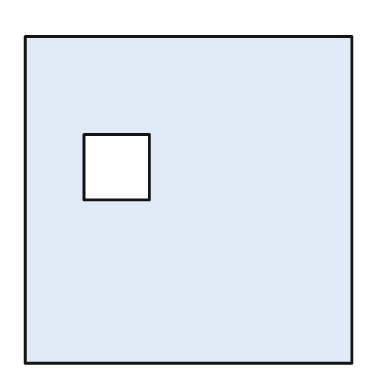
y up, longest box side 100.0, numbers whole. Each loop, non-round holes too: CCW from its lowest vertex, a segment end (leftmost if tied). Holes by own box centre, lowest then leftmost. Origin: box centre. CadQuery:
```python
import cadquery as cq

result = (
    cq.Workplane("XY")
    .moveTo(-50.0, -50.0)
    .lineTo(50.0, -50.0)
    .lineTo(50.0, 50.0)
    .lineTo(-50.0, 50.0)
    .close()
    .moveTo(-32.0, 0.0)
    .lineTo(-12.0, 0.0)
    .lineTo(-12.0, 20.0)
    .lineTo(-32.0, 20.0)
    .close()
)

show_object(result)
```